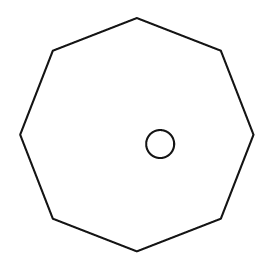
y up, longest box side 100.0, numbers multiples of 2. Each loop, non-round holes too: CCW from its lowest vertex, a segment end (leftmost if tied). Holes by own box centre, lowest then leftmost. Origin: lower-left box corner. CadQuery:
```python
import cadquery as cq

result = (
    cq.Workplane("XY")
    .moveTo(50.0, 0.0)
    .lineTo(86.0, 14.0)
    .lineTo(100.0, 50.0)
    .lineTo(86.0, 86.0)
    .lineTo(50.0, 100.0)
    .lineTo(14.0, 86.0)
    .lineTo(0.0, 50.0)
    .lineTo(14.0, 14.0)
    .close()
    .moveTo(60.0, 46.0)
    .circle(6.0)
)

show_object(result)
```